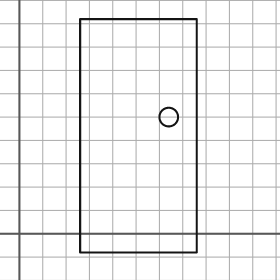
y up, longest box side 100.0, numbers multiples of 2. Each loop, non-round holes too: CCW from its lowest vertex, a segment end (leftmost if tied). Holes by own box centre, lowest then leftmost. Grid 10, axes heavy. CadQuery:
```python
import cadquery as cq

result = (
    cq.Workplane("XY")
    .moveTo(26.0, -8.0)
    .lineTo(76.0, -8.0)
    .lineTo(76.0, 92.0)
    .lineTo(26.0, 92.0)
    .close()
    .moveTo(64.0, 50.0)
    .circle(4.0)
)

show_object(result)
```